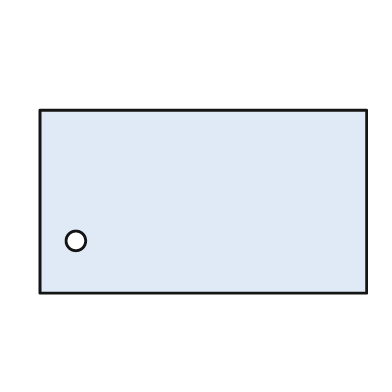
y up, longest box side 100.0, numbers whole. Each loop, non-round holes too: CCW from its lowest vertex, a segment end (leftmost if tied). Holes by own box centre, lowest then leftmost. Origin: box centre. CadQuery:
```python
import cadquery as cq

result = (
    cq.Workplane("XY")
    .moveTo(-50.0, -28.0)
    .lineTo(50.0, -28.0)
    .lineTo(50.0, 28.0)
    .lineTo(-50.0, 28.0)
    .close()
    .moveTo(-39.0, -12.0)
    .circle(3.0)
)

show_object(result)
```